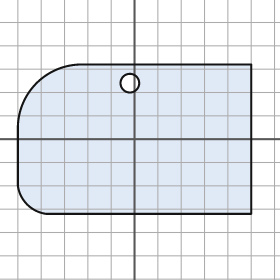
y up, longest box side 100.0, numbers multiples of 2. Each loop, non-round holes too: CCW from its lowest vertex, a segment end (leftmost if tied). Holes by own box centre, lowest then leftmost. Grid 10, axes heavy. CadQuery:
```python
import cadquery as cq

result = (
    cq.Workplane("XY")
    .moveTo(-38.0, -32.0)
    .lineTo(50.0, -32.0)
    .lineTo(50.0, 32.0)
    .lineTo(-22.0, 32.0)
    .threePointArc((-42.0, 24.0), (-50.0, 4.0))
    .lineTo(-50.0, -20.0)
    .threePointArc((-46.0, -28.0), (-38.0, -32.0))
    .close()
    .moveTo(-2.0, 24.0)
    .circle(4.0)
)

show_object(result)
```